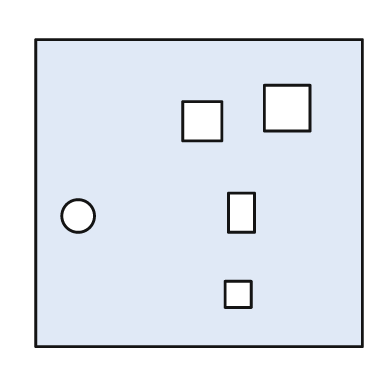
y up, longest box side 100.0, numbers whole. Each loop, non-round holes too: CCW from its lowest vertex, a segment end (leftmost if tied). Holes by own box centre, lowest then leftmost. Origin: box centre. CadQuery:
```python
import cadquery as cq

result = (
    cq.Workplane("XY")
    .moveTo(-50.0, -47.0)
    .lineTo(50.0, -47.0)
    .lineTo(50.0, 47.0)
    .lineTo(-50.0, 47.0)
    .close()
    .moveTo(8.0, -35.0)
    .lineTo(16.0, -35.0)
    .lineTo(16.0, -27.0)
    .lineTo(8.0, -27.0)
    .close()
    .moveTo(-37.0, -7.0)
    .circle(5.0)
    .moveTo(9.0, -12.0)
    .lineTo(17.0, -12.0)
    .lineTo(17.0, 0.0)
    .lineTo(9.0, 0.0)
    .close()
    .moveTo(-5.0, 16.0)
    .lineTo(7.0, 16.0)
    .lineTo(7.0, 28.0)
    .lineTo(-5.0, 28.0)
    .close()
    .moveTo(20.0, 19.0)
    .lineTo(34.0, 19.0)
    .lineTo(34.0, 33.0)
    .lineTo(20.0, 33.0)
    .close()
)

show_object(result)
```